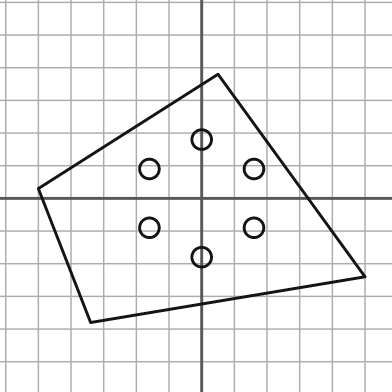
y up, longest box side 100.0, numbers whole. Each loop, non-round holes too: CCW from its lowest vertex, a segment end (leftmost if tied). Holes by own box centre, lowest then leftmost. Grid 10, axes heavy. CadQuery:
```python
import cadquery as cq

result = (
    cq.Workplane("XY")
    .moveTo(-34.0, -38.0)
    .lineTo(50.0, -24.0)
    .lineTo(5.0, 38.0)
    .lineTo(-50.0, 3.0)
    .close()
    .moveTo(0.0, -18.0)
    .circle(3.0)
    .moveTo(-16.0, -9.0)
    .circle(3.0)
    .moveTo(16.0, -9.0)
    .circle(3.0)
    .moveTo(-16.0, 9.0)
    .circle(3.0)
    .moveTo(16.0, 9.0)
    .circle(3.0)
    .moveTo(0.0, 18.0)
    .circle(3.0)
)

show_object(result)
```